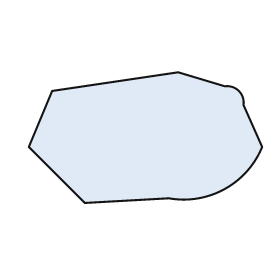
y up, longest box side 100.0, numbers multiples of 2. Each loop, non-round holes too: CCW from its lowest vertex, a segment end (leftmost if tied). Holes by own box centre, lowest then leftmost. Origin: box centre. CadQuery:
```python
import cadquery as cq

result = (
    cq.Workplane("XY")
    .moveTo(-26.0, -28.0)
    .lineTo(10.0, -26.0)
    .threePointArc((34.0, -22.0), (50.0, -4.0))
    .lineTo(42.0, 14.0)
    .threePointArc((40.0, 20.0), (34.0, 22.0))
    .lineTo(14.0, 28.0)
    .lineTo(-40.0, 20.0)
    .lineTo(-50.0, -4.0)
    .close()
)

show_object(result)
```